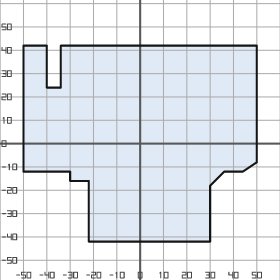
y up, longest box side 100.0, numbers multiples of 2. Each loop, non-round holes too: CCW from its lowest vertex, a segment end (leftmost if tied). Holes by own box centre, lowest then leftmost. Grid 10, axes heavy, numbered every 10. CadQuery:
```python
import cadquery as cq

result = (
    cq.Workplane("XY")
    .moveTo(-22.0, -42.0)
    .lineTo(30.0, -42.0)
    .lineTo(30.0, -18.0)
    .lineTo(36.0, -12.0)
    .lineTo(44.0, -12.0)
    .lineTo(50.0, -8.0)
    .lineTo(50.0, 42.0)
    .lineTo(-34.0, 42.0)
    .lineTo(-34.0, 24.0)
    .lineTo(-40.0, 24.0)
    .lineTo(-40.0, 42.0)
    .lineTo(-50.0, 42.0)
    .lineTo(-50.0, -12.0)
    .lineTo(-30.0, -12.0)
    .lineTo(-30.0, -16.0)
    .lineTo(-22.0, -16.0)
    .close()
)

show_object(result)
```